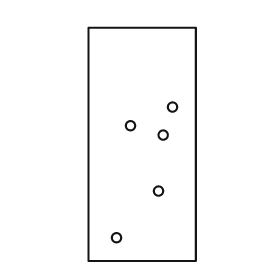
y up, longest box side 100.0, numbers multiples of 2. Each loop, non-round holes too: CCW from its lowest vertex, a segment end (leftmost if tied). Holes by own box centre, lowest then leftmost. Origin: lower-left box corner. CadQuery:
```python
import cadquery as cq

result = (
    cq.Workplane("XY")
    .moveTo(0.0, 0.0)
    .lineTo(46.0, 0.0)
    .lineTo(46.0, 100.0)
    .lineTo(0.0, 100.0)
    .close()
    .moveTo(12.0, 10.0)
    .circle(2.0)
    .moveTo(30.0, 30.0)
    .circle(2.0)
    .moveTo(32.0, 54.0)
    .circle(2.0)
    .moveTo(18.0, 58.0)
    .circle(2.0)
    .moveTo(36.0, 66.0)
    .circle(2.0)
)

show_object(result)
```